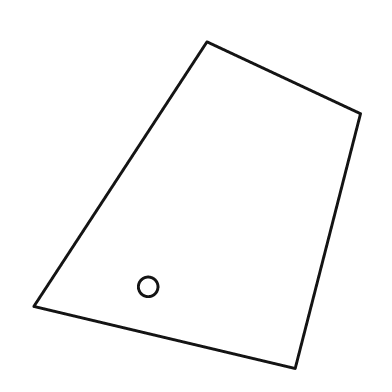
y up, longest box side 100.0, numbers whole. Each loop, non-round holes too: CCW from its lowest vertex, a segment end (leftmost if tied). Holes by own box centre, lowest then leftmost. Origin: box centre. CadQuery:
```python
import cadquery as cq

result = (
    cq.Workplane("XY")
    .moveTo(30.0, -50.0)
    .lineTo(50.0, 28.0)
    .lineTo(3.0, 50.0)
    .lineTo(-50.0, -31.0)
    .close()
    .moveTo(-15.0, -25.0)
    .circle(3.0)
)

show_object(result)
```